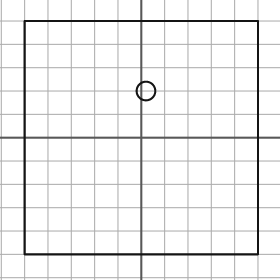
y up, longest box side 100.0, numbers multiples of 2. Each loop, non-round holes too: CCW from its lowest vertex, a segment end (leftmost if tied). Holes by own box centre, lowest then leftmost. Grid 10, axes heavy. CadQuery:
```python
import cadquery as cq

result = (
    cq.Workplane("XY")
    .moveTo(-50.0, -50.0)
    .lineTo(50.0, -50.0)
    .lineTo(50.0, 50.0)
    .lineTo(-50.0, 50.0)
    .close()
    .moveTo(2.0, 20.0)
    .circle(4.0)
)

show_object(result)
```